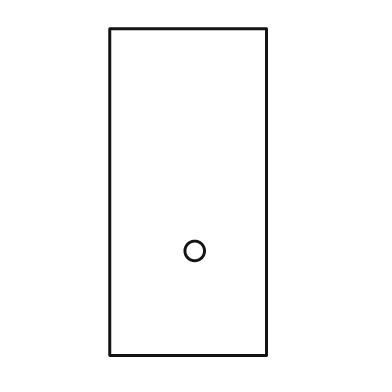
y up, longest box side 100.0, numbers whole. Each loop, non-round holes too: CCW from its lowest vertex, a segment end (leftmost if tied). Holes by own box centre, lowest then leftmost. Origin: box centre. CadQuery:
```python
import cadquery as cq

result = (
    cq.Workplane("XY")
    .moveTo(-24.0, -50.0)
    .lineTo(24.0, -50.0)
    .lineTo(24.0, 50.0)
    .lineTo(-24.0, 50.0)
    .close()
    .moveTo(2.0, -18.0)
    .circle(3.0)
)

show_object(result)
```